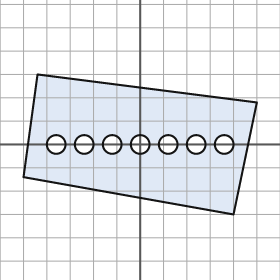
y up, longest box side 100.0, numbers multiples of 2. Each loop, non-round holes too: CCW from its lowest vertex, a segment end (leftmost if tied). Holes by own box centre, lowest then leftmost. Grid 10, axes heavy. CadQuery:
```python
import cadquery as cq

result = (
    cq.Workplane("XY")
    .moveTo(40.0, -30.0)
    .lineTo(50.0, 18.0)
    .lineTo(-44.0, 30.0)
    .lineTo(-50.0, -14.0)
    .close()
    .moveTo(-36.0, 0.0)
    .circle(4.0)
    .moveTo(-24.0, 0.0)
    .circle(4.0)
    .moveTo(-12.0, 0.0)
    .circle(4.0)
    .moveTo(0.0, 0.0)
    .circle(4.0)
    .moveTo(12.0, 0.0)
    .circle(4.0)
    .moveTo(24.0, 0.0)
    .circle(4.0)
    .moveTo(36.0, 0.0)
    .circle(4.0)
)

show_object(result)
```